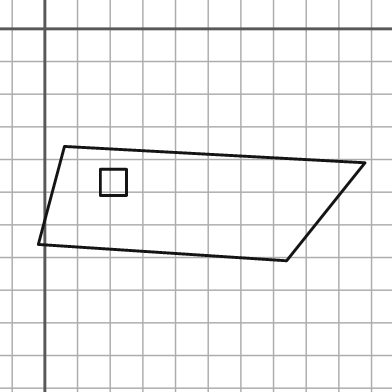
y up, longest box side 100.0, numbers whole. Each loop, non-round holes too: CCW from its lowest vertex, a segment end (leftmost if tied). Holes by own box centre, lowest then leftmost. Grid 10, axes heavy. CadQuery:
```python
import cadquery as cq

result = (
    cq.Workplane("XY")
    .moveTo(74.0, -71.0)
    .lineTo(98.0, -41.0)
    .lineTo(6.0, -36.0)
    .lineTo(-2.0, -66.0)
    .close()
    .moveTo(17.0, -51.0)
    .lineTo(25.0, -51.0)
    .lineTo(25.0, -43.0)
    .lineTo(17.0, -43.0)
    .close()
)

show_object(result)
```